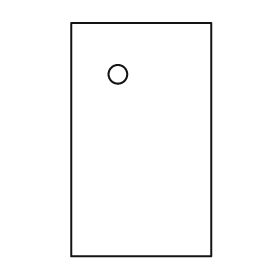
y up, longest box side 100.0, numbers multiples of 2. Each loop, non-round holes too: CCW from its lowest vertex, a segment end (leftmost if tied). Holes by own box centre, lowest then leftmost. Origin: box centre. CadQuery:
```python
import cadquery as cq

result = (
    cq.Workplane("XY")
    .moveTo(-30.0, -50.0)
    .lineTo(30.0, -50.0)
    .lineTo(30.0, 50.0)
    .lineTo(-30.0, 50.0)
    .close()
    .moveTo(-10.0, 28.0)
    .circle(4.0)
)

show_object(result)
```